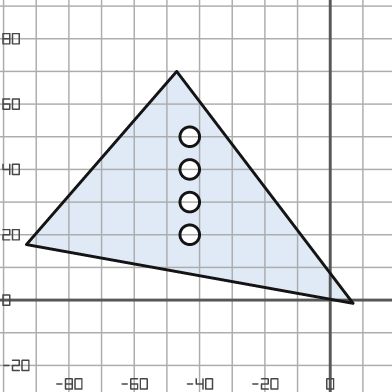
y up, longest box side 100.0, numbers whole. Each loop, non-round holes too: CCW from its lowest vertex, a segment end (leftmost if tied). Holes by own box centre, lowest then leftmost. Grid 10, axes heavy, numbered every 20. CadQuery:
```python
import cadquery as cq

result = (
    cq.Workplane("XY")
    .moveTo(7.0, -1.0)
    .lineTo(-47.0, 70.0)
    .lineTo(-93.0, 17.0)
    .close()
    .moveTo(-43.0, 20.0)
    .circle(3.0)
    .moveTo(-43.0, 30.0)
    .circle(3.0)
    .moveTo(-43.0, 40.0)
    .circle(3.0)
    .moveTo(-43.0, 50.0)
    .circle(3.0)
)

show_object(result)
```